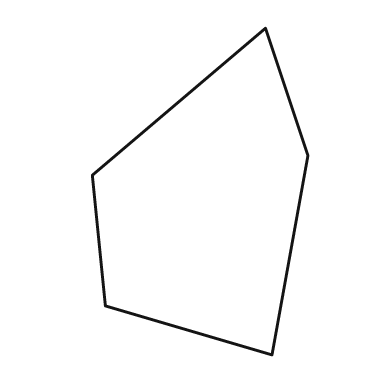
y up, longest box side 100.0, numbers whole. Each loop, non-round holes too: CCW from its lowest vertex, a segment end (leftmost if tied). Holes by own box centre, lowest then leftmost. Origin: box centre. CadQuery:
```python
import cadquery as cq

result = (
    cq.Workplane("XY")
    .moveTo(22.0, -50.0)
    .lineTo(33.0, 11.0)
    .lineTo(20.0, 50.0)
    .lineTo(-33.0, 5.0)
    .lineTo(-29.0, -35.0)
    .close()
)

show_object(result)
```